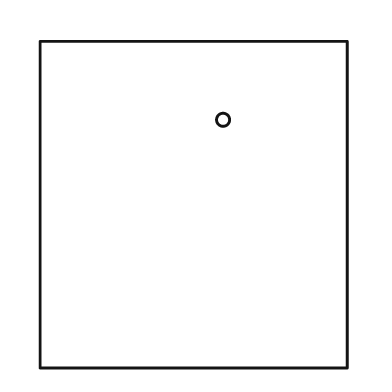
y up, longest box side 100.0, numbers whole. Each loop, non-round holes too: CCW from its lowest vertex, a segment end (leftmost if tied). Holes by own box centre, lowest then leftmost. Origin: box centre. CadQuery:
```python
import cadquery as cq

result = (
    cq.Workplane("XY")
    .moveTo(-47.0, -50.0)
    .lineTo(47.0, -50.0)
    .lineTo(47.0, 50.0)
    .lineTo(-47.0, 50.0)
    .close()
    .moveTo(9.0, 26.0)
    .circle(2.0)
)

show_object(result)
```